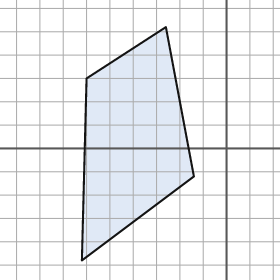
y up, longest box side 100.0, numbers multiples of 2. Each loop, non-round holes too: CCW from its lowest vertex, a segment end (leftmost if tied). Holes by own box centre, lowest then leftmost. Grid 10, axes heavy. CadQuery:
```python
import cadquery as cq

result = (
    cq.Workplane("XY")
    .moveTo(-62.0, -48.0)
    .lineTo(-14.0, -12.0)
    .lineTo(-26.0, 52.0)
    .lineTo(-60.0, 30.0)
    .close()
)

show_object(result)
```